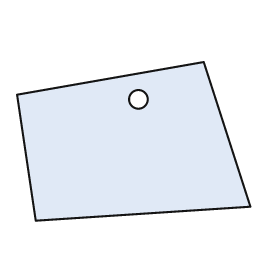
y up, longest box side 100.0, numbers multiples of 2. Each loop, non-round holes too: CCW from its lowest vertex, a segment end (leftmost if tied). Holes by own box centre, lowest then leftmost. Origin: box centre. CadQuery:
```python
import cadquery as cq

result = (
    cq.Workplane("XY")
    .moveTo(-42.0, -34.0)
    .lineTo(50.0, -28.0)
    .lineTo(30.0, 34.0)
    .lineTo(-50.0, 20.0)
    .close()
    .moveTo(2.0, 18.0)
    .circle(4.0)
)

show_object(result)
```